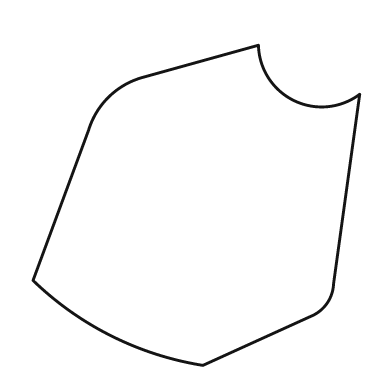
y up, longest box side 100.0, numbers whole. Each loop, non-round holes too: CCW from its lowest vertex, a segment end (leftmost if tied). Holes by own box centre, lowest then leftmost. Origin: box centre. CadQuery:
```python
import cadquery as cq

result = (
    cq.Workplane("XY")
    .moveTo(2.0, -49.0)
    .lineTo(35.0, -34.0)
    .threePointArc((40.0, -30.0), (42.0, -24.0))
    .lineTo(50.0, 34.0)
    .threePointArc((30.0, 32.0), (19.0, 49.0))
    .lineTo(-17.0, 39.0)
    .threePointArc((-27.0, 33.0), (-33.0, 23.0))
    .lineTo(-50.0, -23.0)
    .threePointArc((-26.0, -40.0), (2.0, -49.0))
    .close()
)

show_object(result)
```